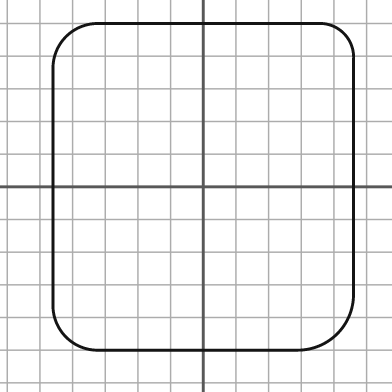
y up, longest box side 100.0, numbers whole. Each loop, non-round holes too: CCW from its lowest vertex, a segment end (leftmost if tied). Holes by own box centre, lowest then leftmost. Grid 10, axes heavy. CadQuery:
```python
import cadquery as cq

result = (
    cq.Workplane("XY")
    .moveTo(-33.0, -50.0)
    .lineTo(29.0, -50.0)
    .threePointArc((41.0, -45.0), (46.0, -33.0))
    .lineTo(46.0, 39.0)
    .threePointArc((43.0, 47.0), (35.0, 50.0))
    .lineTo(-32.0, 50.0)
    .threePointArc((-42.0, 46.0), (-46.0, 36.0))
    .lineTo(-46.0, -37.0)
    .threePointArc((-42.0, -46.0), (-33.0, -50.0))
    .close()
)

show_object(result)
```